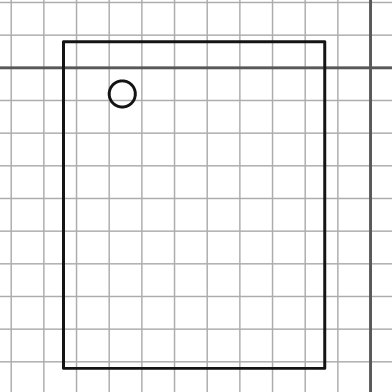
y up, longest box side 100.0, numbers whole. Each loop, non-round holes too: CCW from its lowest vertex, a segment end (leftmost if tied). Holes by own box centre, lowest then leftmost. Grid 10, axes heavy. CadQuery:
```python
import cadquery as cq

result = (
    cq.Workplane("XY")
    .moveTo(-94.0, -92.0)
    .lineTo(-14.0, -92.0)
    .lineTo(-14.0, 8.0)
    .lineTo(-94.0, 8.0)
    .close()
    .moveTo(-76.0, -8.0)
    .circle(4.0)
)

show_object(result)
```